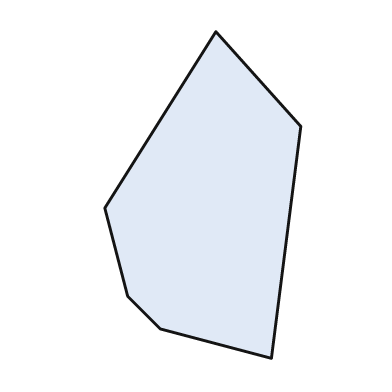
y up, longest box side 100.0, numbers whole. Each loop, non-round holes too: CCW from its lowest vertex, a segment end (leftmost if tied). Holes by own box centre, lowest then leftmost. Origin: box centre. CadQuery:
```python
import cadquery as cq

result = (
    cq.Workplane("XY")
    .moveTo(21.0, -50.0)
    .lineTo(30.0, 21.0)
    .lineTo(4.0, 50.0)
    .lineTo(-30.0, -4.0)
    .lineTo(-23.0, -31.0)
    .lineTo(-13.0, -41.0)
    .close()
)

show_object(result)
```